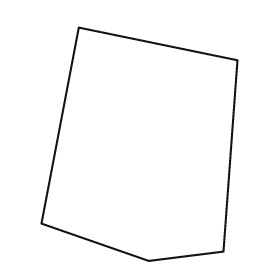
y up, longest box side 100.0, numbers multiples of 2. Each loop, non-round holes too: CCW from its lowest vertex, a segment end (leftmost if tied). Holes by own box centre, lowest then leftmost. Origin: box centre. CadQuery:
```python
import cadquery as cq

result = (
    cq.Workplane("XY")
    .moveTo(4.0, -50.0)
    .lineTo(36.0, -46.0)
    .lineTo(42.0, 36.0)
    .lineTo(-26.0, 50.0)
    .lineTo(-42.0, -34.0)
    .close()
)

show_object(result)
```